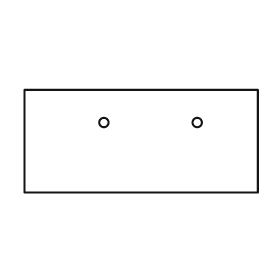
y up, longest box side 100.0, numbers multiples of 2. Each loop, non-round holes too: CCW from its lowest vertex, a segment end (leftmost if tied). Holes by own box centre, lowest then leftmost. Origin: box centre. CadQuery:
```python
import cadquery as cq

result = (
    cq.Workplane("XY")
    .moveTo(-50.0, -22.0)
    .lineTo(50.0, -22.0)
    .lineTo(50.0, 22.0)
    .lineTo(-50.0, 22.0)
    .close()
    .moveTo(-16.0, 8.0)
    .circle(2.0)
    .moveTo(24.0, 8.0)
    .circle(2.0)
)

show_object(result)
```